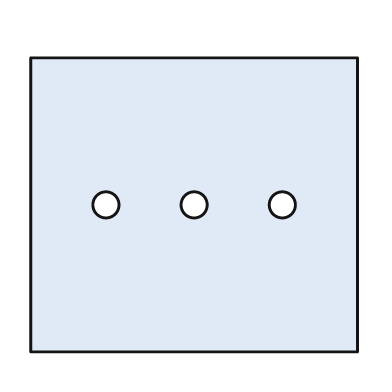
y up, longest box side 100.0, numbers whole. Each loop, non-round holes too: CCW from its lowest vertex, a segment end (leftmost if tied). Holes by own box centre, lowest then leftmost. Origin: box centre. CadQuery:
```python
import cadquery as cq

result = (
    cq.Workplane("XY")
    .moveTo(-50.0, -45.0)
    .lineTo(50.0, -45.0)
    .lineTo(50.0, 45.0)
    .lineTo(-50.0, 45.0)
    .close()
    .moveTo(-27.0, 0.0)
    .circle(4.0)
    .moveTo(0.0, 0.0)
    .circle(4.0)
    .moveTo(27.0, 0.0)
    .circle(4.0)
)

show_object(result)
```